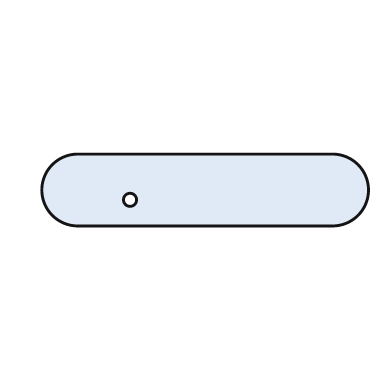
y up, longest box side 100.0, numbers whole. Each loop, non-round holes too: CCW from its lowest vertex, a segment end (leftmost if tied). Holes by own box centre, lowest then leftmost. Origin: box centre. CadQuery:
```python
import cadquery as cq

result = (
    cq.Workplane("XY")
    .moveTo(-39.0, -11.0)
    .lineTo(39.0, -11.0)
    .threePointArc((50.0, 0.0), (39.0, 11.0))
    .lineTo(-39.0, 11.0)
    .threePointArc((-50.0, 0.0), (-39.0, -11.0))
    .close()
    .moveTo(-23.0, -3.0)
    .circle(2.0)
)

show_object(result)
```